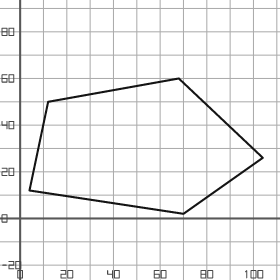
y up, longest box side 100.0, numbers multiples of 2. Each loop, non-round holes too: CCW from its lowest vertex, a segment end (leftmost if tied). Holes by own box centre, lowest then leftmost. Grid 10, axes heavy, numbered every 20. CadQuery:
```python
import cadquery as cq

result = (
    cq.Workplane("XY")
    .moveTo(70.0, 2.0)
    .lineTo(104.0, 26.0)
    .lineTo(68.0, 60.0)
    .lineTo(12.0, 50.0)
    .lineTo(4.0, 12.0)
    .close()
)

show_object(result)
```